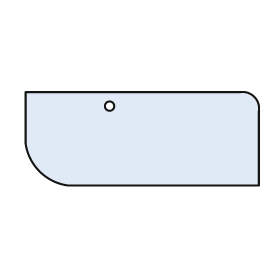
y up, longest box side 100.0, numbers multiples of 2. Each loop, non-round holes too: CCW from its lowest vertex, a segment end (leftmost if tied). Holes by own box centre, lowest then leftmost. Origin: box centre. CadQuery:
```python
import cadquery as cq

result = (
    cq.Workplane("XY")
    .moveTo(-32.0, -20.0)
    .lineTo(50.0, -20.0)
    .lineTo(50.0, 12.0)
    .threePointArc((48.0, 18.0), (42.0, 20.0))
    .lineTo(-50.0, 20.0)
    .lineTo(-50.0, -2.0)
    .threePointArc((-44.0, -14.0), (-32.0, -20.0))
    .close()
    .moveTo(-14.0, 14.0)
    .circle(2.0)
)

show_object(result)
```